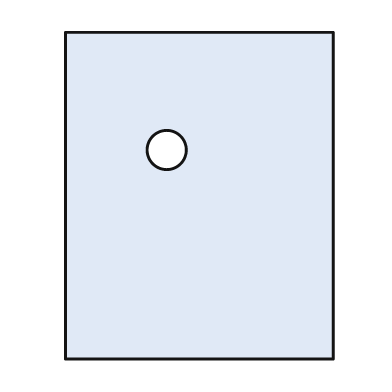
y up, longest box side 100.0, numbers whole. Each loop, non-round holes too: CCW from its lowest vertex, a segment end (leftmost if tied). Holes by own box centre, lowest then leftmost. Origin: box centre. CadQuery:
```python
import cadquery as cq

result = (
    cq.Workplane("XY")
    .moveTo(-41.0, -50.0)
    .lineTo(41.0, -50.0)
    .lineTo(41.0, 50.0)
    .lineTo(-41.0, 50.0)
    .close()
    .moveTo(-10.0, 14.0)
    .circle(6.0)
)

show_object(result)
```